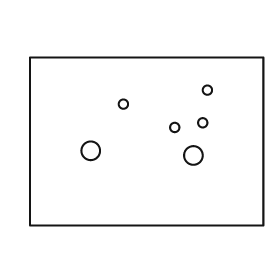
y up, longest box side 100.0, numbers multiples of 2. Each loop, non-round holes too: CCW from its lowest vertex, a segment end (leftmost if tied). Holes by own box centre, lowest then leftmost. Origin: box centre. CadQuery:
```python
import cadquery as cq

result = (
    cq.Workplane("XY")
    .moveTo(-50.0, -36.0)
    .lineTo(50.0, -36.0)
    .lineTo(50.0, 36.0)
    .lineTo(-50.0, 36.0)
    .close()
    .moveTo(20.0, -6.0)
    .circle(4.0)
    .moveTo(-24.0, -4.0)
    .circle(4.0)
    .moveTo(12.0, 6.0)
    .circle(2.0)
    .moveTo(24.0, 8.0)
    .circle(2.0)
    .moveTo(-10.0, 16.0)
    .circle(2.0)
    .moveTo(26.0, 22.0)
    .circle(2.0)
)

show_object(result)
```